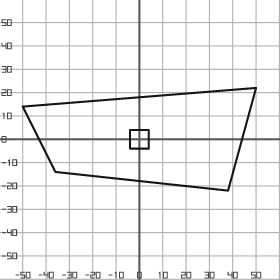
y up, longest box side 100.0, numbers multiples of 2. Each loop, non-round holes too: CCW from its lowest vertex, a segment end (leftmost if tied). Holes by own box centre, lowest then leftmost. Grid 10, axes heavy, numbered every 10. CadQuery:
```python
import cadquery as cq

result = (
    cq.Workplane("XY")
    .moveTo(38.0, -22.0)
    .lineTo(50.0, 22.0)
    .lineTo(-50.0, 14.0)
    .lineTo(-36.0, -14.0)
    .close()
    .moveTo(-4.0, -4.0)
    .lineTo(4.0, -4.0)
    .lineTo(4.0, 4.0)
    .lineTo(-4.0, 4.0)
    .close()
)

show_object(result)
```